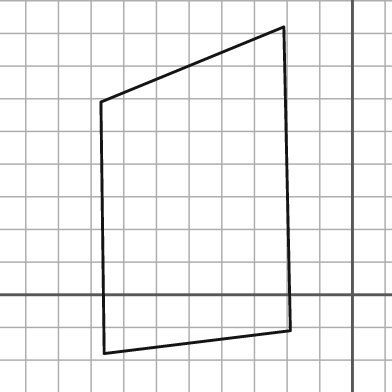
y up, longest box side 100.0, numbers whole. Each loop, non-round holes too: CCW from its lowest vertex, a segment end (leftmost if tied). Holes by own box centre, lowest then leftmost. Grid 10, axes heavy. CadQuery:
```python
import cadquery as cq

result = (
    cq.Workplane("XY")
    .moveTo(-76.0, -18.0)
    .lineTo(-19.0, -11.0)
    .lineTo(-21.0, 82.0)
    .lineTo(-77.0, 59.0)
    .close()
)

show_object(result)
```